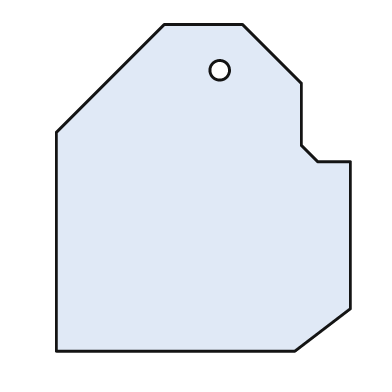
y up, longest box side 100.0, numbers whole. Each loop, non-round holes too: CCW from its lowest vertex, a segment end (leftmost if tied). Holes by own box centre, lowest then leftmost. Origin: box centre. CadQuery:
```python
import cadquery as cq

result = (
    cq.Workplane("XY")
    .moveTo(-45.0, -50.0)
    .lineTo(28.0, -50.0)
    .lineTo(45.0, -37.0)
    .lineTo(45.0, 8.0)
    .lineTo(35.0, 8.0)
    .lineTo(30.0, 13.0)
    .lineTo(30.0, 32.0)
    .lineTo(12.0, 50.0)
    .lineTo(-12.0, 50.0)
    .lineTo(-45.0, 17.0)
    .close()
    .moveTo(5.0, 36.0)
    .circle(3.0)
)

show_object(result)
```